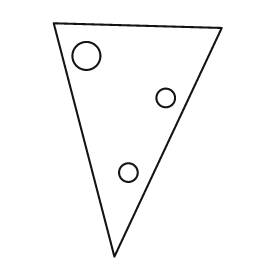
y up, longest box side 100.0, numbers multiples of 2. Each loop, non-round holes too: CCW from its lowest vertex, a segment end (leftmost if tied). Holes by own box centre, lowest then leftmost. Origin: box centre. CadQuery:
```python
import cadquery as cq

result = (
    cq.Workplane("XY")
    .moveTo(-10.0, -50.0)
    .lineTo(36.0, 48.0)
    .lineTo(-36.0, 50.0)
    .close()
    .moveTo(-4.0, -14.0)
    .circle(4.0)
    .moveTo(12.0, 18.0)
    .circle(4.0)
    .moveTo(-22.0, 36.0)
    .circle(6.0)
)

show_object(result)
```